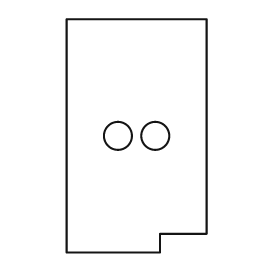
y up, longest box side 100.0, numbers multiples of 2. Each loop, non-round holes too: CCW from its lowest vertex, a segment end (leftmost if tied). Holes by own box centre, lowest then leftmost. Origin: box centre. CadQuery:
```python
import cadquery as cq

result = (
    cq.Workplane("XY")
    .moveTo(-30.0, -50.0)
    .lineTo(10.0, -50.0)
    .lineTo(10.0, -42.0)
    .lineTo(30.0, -42.0)
    .lineTo(30.0, 50.0)
    .lineTo(-30.0, 50.0)
    .close()
    .moveTo(-8.0, 0.0)
    .circle(6.0)
    .moveTo(8.0, 0.0)
    .circle(6.0)
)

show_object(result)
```